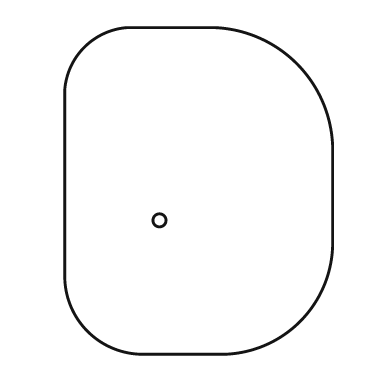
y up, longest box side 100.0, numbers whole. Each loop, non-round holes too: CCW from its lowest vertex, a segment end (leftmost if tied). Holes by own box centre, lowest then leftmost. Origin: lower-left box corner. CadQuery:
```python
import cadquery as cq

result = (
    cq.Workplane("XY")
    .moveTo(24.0, 0.0)
    .lineTo(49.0, 0.0)
    .threePointArc((72.0, 10.0), (82.0, 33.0))
    .lineTo(82.0, 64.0)
    .threePointArc((71.0, 89.0), (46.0, 100.0))
    .lineTo(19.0, 100.0)
    .threePointArc((6.0, 94.0), (0.0, 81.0))
    .lineTo(0.0, 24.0)
    .threePointArc((7.0, 7.0), (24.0, 0.0))
    .close()
    .moveTo(29.0, 41.0)
    .circle(2.0)
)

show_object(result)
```